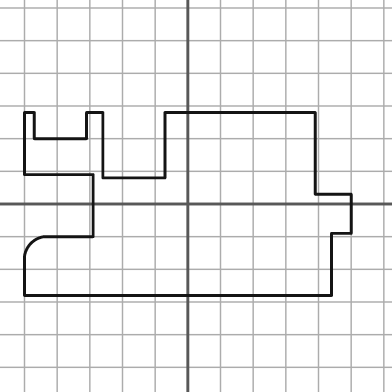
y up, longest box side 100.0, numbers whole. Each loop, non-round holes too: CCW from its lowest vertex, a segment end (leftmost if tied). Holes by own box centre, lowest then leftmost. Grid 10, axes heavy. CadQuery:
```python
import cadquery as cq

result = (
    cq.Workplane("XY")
    .moveTo(-50.0, -28.0)
    .lineTo(44.0, -28.0)
    .lineTo(44.0, -9.0)
    .lineTo(50.0, -9.0)
    .lineTo(50.0, 3.0)
    .lineTo(39.0, 3.0)
    .lineTo(39.0, 28.0)
    .lineTo(-7.0, 28.0)
    .lineTo(-7.0, 8.0)
    .lineTo(-26.0, 8.0)
    .lineTo(-26.0, 28.0)
    .lineTo(-31.0, 28.0)
    .lineTo(-31.0, 20.0)
    .lineTo(-47.0, 20.0)
    .lineTo(-47.0, 28.0)
    .lineTo(-50.0, 28.0)
    .lineTo(-50.0, 9.0)
    .lineTo(-29.0, 9.0)
    .lineTo(-29.0, -10.0)
    .lineTo(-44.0, -10.0)
    .threePointArc((-48.0, -12.0), (-50.0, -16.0))
    .close()
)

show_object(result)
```